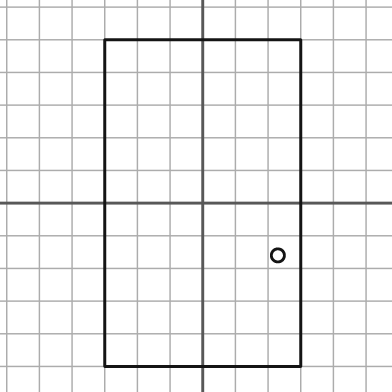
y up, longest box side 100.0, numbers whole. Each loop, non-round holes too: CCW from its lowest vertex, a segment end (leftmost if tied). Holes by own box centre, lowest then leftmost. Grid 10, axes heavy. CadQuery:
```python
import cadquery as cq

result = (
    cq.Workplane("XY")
    .moveTo(-30.0, -50.0)
    .lineTo(30.0, -50.0)
    .lineTo(30.0, 50.0)
    .lineTo(-30.0, 50.0)
    .close()
    .moveTo(23.0, -16.0)
    .circle(2.0)
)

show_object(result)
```